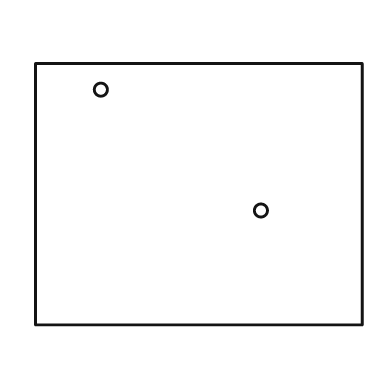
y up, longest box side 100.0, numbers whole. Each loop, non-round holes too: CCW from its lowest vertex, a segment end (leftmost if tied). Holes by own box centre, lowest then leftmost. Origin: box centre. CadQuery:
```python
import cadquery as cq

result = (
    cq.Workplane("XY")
    .moveTo(-50.0, -40.0)
    .lineTo(50.0, -40.0)
    .lineTo(50.0, 40.0)
    .lineTo(-50.0, 40.0)
    .close()
    .moveTo(19.0, -5.0)
    .circle(2.0)
    .moveTo(-30.0, 32.0)
    .circle(2.0)
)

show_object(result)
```